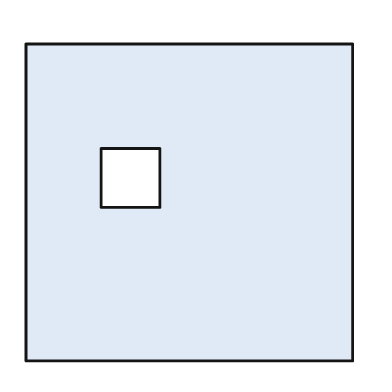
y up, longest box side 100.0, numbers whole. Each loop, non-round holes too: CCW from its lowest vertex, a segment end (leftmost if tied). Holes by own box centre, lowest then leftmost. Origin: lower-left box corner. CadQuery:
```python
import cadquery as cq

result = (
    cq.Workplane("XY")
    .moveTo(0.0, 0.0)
    .lineTo(100.0, 0.0)
    .lineTo(100.0, 97.0)
    .lineTo(0.0, 97.0)
    .close()
    .moveTo(23.0, 47.0)
    .lineTo(41.0, 47.0)
    .lineTo(41.0, 65.0)
    .lineTo(23.0, 65.0)
    .close()
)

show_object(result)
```